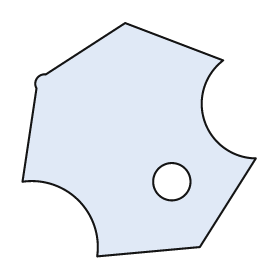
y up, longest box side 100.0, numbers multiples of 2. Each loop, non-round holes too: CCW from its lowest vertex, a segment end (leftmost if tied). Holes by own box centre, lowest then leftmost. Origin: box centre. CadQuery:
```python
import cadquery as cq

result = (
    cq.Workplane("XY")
    .moveTo(-18.0, -50.0)
    .lineTo(26.0, -46.0)
    .lineTo(50.0, -8.0)
    .threePointArc((28.0, 8.0), (36.0, 34.0))
    .lineTo(-6.0, 50.0)
    .lineTo(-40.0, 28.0)
    .threePointArc((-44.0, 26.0), (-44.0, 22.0))
    .lineTo(-50.0, -18.0)
    .threePointArc((-26.0, -26.0), (-18.0, -50.0))
    .close()
    .moveTo(14.0, -18.0)
    .circle(8.0)
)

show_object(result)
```